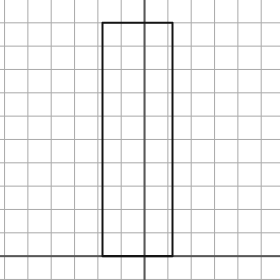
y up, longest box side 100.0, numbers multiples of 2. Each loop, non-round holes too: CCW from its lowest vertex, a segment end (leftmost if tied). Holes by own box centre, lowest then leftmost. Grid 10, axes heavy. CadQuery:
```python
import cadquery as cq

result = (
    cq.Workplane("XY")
    .moveTo(-18.0, 0.0)
    .lineTo(12.0, 0.0)
    .lineTo(12.0, 100.0)
    .lineTo(-18.0, 100.0)
    .close()
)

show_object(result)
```